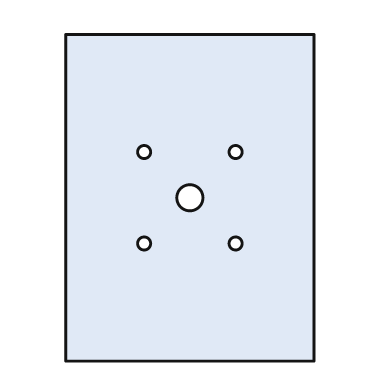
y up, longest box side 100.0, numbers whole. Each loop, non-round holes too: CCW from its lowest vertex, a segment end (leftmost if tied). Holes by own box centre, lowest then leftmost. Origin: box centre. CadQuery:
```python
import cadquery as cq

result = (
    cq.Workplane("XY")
    .moveTo(-38.0, -50.0)
    .lineTo(38.0, -50.0)
    .lineTo(38.0, 50.0)
    .lineTo(-38.0, 50.0)
    .close()
    .moveTo(-14.0, -14.0)
    .circle(2.0)
    .moveTo(14.0, -14.0)
    .circle(2.0)
    .moveTo(0.0, 0.0)
    .circle(4.0)
    .moveTo(-14.0, 14.0)
    .circle(2.0)
    .moveTo(14.0, 14.0)
    .circle(2.0)
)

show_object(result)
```